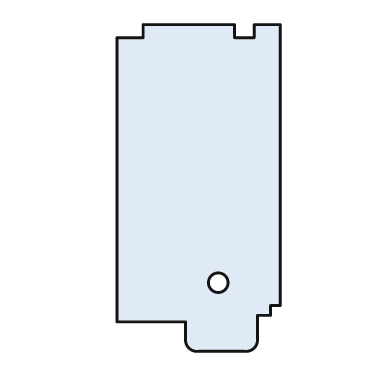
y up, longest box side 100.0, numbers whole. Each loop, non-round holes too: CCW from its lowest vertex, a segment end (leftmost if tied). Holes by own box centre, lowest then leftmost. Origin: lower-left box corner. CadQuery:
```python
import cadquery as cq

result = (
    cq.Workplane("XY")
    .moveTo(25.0, 0.0)
    .lineTo(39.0, 0.0)
    .threePointArc((42.0, 1.0), (43.0, 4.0))
    .lineTo(43.0, 11.0)
    .lineTo(47.0, 11.0)
    .lineTo(47.0, 14.0)
    .lineTo(50.0, 14.0)
    .lineTo(50.0, 100.0)
    .lineTo(42.0, 100.0)
    .lineTo(42.0, 96.0)
    .lineTo(36.0, 96.0)
    .lineTo(36.0, 100.0)
    .lineTo(8.0, 100.0)
    .lineTo(8.0, 96.0)
    .lineTo(0.0, 96.0)
    .lineTo(0.0, 9.0)
    .lineTo(21.0, 9.0)
    .lineTo(21.0, 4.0)
    .threePointArc((22.0, 1.0), (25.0, 0.0))
    .close()
    .moveTo(31.0, 21.0)
    .circle(3.0)
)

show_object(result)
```